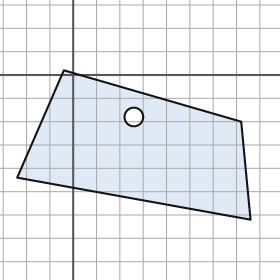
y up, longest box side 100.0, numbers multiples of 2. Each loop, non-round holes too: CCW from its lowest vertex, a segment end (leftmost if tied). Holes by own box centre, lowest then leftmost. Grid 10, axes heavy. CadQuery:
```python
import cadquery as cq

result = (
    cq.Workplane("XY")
    .moveTo(76.0, -62.0)
    .lineTo(72.0, -20.0)
    .lineTo(-4.0, 2.0)
    .lineTo(-24.0, -44.0)
    .close()
    .moveTo(26.0, -18.0)
    .circle(4.0)
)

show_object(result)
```